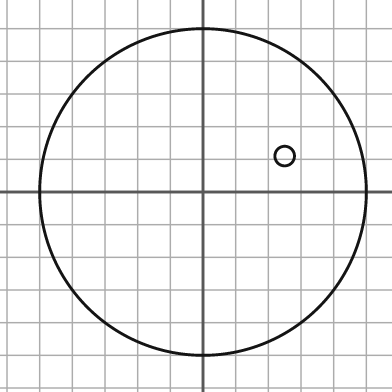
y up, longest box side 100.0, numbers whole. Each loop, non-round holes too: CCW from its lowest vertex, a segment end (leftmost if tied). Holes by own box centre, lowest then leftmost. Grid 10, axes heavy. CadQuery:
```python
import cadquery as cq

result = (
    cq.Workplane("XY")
    .moveTo(0.0, 0.0)
    .circle(50.0)
    .moveTo(25.0, 11.0)
    .circle(3.0)
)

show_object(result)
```